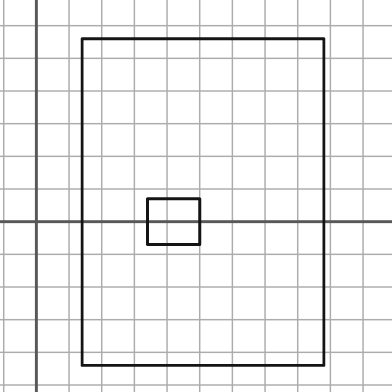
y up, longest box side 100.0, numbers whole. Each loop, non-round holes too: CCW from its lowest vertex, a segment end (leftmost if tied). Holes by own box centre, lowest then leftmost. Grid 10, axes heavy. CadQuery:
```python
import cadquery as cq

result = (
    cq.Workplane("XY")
    .moveTo(14.0, -44.0)
    .lineTo(88.0, -44.0)
    .lineTo(88.0, 56.0)
    .lineTo(14.0, 56.0)
    .close()
    .moveTo(34.0, -7.0)
    .lineTo(50.0, -7.0)
    .lineTo(50.0, 7.0)
    .lineTo(34.0, 7.0)
    .close()
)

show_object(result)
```